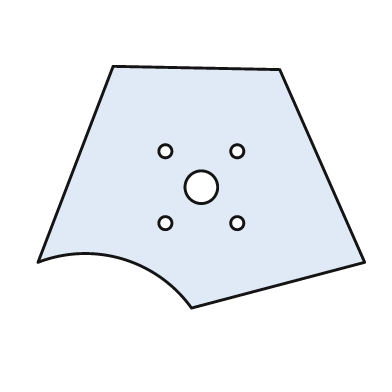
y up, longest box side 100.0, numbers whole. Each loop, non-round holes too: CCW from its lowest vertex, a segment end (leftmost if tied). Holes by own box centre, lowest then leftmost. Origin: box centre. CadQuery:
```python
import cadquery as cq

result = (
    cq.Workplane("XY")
    .moveTo(-3.0, -37.0)
    .lineTo(50.0, -23.0)
    .lineTo(24.0, 36.0)
    .lineTo(-27.0, 37.0)
    .lineTo(-50.0, -23.0)
    .threePointArc((-24.0, -22.0), (-3.0, -37.0))
    .close()
    .moveTo(-11.0, -11.0)
    .circle(2.0)
    .moveTo(11.0, -11.0)
    .circle(2.0)
    .moveTo(0.0, 0.0)
    .circle(5.0)
    .moveTo(-11.0, 11.0)
    .circle(2.0)
    .moveTo(11.0, 11.0)
    .circle(2.0)
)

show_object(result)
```